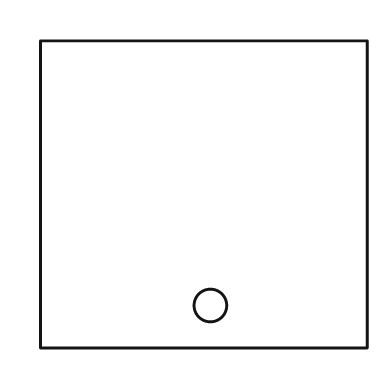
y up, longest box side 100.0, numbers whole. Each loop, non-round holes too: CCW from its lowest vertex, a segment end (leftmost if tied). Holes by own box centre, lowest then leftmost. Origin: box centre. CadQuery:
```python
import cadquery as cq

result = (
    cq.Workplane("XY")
    .moveTo(-50.0, -47.0)
    .lineTo(50.0, -47.0)
    .lineTo(50.0, 47.0)
    .lineTo(-50.0, 47.0)
    .close()
    .moveTo(2.0, -34.0)
    .circle(5.0)
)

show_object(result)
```